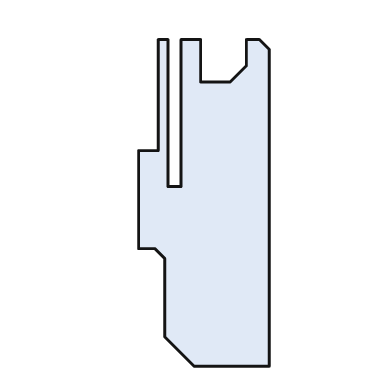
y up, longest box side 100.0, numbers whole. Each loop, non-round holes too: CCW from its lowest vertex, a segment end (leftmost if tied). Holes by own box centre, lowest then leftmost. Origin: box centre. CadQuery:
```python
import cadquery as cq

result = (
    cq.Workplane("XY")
    .moveTo(-3.0, -50.0)
    .lineTo(20.0, -50.0)
    .lineTo(20.0, 47.0)
    .lineTo(17.0, 50.0)
    .lineTo(13.0, 50.0)
    .lineTo(13.0, 42.0)
    .lineTo(8.0, 37.0)
    .lineTo(-1.0, 37.0)
    .lineTo(-1.0, 50.0)
    .lineTo(-7.0, 50.0)
    .lineTo(-7.0, 5.0)
    .lineTo(-11.0, 5.0)
    .lineTo(-11.0, 50.0)
    .lineTo(-14.0, 50.0)
    .lineTo(-14.0, 16.0)
    .lineTo(-20.0, 16.0)
    .lineTo(-20.0, -14.0)
    .lineTo(-15.0, -14.0)
    .lineTo(-12.0, -17.0)
    .lineTo(-12.0, -41.0)
    .close()
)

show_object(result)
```